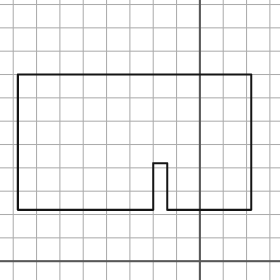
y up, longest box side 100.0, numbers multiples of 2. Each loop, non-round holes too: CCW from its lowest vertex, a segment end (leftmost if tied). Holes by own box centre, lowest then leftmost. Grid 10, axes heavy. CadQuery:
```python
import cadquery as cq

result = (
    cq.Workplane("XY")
    .moveTo(-78.0, 22.0)
    .lineTo(-20.0, 22.0)
    .lineTo(-20.0, 42.0)
    .lineTo(-14.0, 42.0)
    .lineTo(-14.0, 22.0)
    .lineTo(22.0, 22.0)
    .lineTo(22.0, 80.0)
    .lineTo(-78.0, 80.0)
    .close()
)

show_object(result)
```